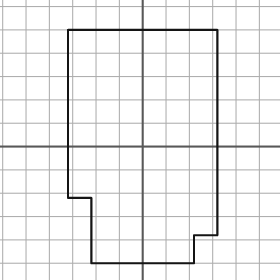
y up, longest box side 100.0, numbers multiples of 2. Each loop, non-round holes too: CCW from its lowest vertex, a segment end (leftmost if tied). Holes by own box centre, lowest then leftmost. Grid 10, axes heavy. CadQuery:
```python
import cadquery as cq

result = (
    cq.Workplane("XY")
    .moveTo(-22.0, -50.0)
    .lineTo(22.0, -50.0)
    .lineTo(22.0, -38.0)
    .lineTo(32.0, -38.0)
    .lineTo(32.0, 50.0)
    .lineTo(-32.0, 50.0)
    .lineTo(-32.0, -22.0)
    .lineTo(-22.0, -22.0)
    .close()
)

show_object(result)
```